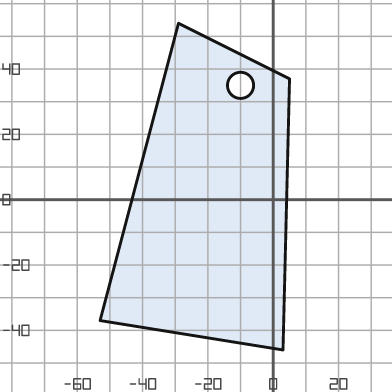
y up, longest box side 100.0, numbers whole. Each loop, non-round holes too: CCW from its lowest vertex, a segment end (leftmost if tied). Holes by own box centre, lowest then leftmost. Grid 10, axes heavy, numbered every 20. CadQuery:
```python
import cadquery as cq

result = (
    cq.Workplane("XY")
    .moveTo(3.0, -46.0)
    .lineTo(5.0, 37.0)
    .lineTo(-29.0, 54.0)
    .lineTo(-53.0, -37.0)
    .close()
    .moveTo(-10.0, 35.0)
    .circle(4.0)
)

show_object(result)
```